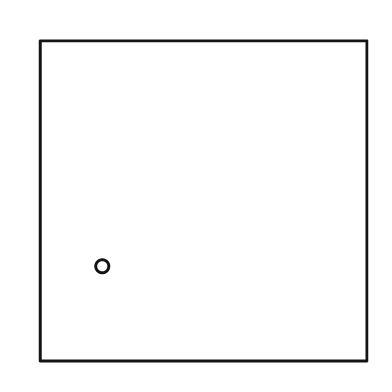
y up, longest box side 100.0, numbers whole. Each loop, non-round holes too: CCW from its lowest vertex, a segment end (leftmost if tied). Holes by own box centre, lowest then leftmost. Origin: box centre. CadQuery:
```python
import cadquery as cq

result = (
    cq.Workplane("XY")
    .moveTo(-50.0, -49.0)
    .lineTo(50.0, -49.0)
    .lineTo(50.0, 49.0)
    .lineTo(-50.0, 49.0)
    .close()
    .moveTo(-31.0, -20.0)
    .circle(2.0)
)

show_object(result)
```